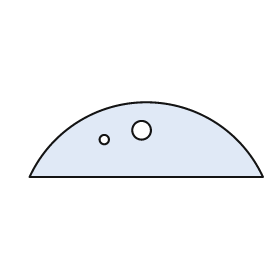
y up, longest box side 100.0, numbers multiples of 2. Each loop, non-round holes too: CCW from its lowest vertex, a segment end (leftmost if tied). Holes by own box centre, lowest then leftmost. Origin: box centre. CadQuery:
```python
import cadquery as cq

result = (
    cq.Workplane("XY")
    .moveTo(-50.0, -16.0)
    .lineTo(50.0, -16.0)
    .threePointArc((0.0, 16.0), (-50.0, -16.0))
    .close()
    .moveTo(-18.0, 0.0)
    .circle(2.0)
    .moveTo(-2.0, 4.0)
    .circle(4.0)
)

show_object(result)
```